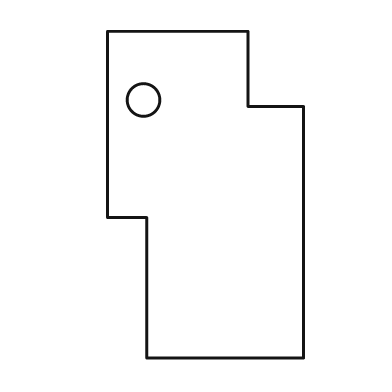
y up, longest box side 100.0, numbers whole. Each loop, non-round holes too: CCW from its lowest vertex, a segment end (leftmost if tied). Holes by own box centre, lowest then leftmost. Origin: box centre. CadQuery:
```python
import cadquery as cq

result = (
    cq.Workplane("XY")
    .moveTo(-18.0, -50.0)
    .lineTo(30.0, -50.0)
    .lineTo(30.0, 27.0)
    .lineTo(13.0, 27.0)
    .lineTo(13.0, 50.0)
    .lineTo(-30.0, 50.0)
    .lineTo(-30.0, -7.0)
    .lineTo(-18.0, -7.0)
    .close()
    .moveTo(-19.0, 29.0)
    .circle(5.0)
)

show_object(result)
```